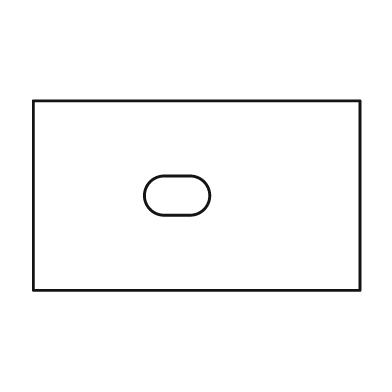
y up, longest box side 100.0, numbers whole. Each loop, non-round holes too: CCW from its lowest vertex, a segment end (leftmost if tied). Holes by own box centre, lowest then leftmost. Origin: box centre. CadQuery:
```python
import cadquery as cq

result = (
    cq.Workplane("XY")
    .moveTo(-50.0, -29.0)
    .lineTo(50.0, -29.0)
    .lineTo(50.0, 29.0)
    .lineTo(-50.0, 29.0)
    .close()
    .moveTo(-10.0, -6.0)
    .lineTo(-2.0, -6.0)
    .threePointArc((4.0, 0.0), (-2.0, 6.0))
    .lineTo(-10.0, 6.0)
    .threePointArc((-16.0, 0.0), (-10.0, -6.0))
    .close()
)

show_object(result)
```